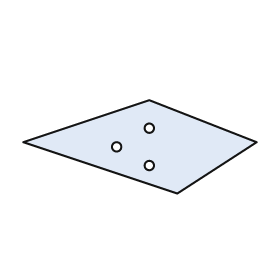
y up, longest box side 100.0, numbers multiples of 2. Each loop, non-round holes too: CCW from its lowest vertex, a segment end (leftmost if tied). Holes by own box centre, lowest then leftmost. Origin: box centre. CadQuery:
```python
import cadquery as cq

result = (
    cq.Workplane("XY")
    .moveTo(16.0, -20.0)
    .lineTo(50.0, 2.0)
    .lineTo(4.0, 20.0)
    .lineTo(-50.0, 2.0)
    .close()
    .moveTo(4.0, -8.0)
    .circle(2.0)
    .moveTo(-10.0, 0.0)
    .circle(2.0)
    .moveTo(4.0, 8.0)
    .circle(2.0)
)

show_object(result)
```